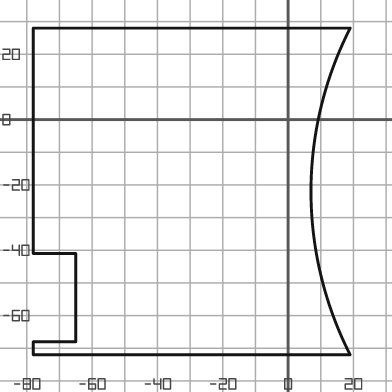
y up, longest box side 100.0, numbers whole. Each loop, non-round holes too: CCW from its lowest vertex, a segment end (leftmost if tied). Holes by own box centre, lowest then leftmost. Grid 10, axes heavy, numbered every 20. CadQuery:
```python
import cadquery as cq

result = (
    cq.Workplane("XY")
    .moveTo(-78.0, -72.0)
    .lineTo(19.0, -72.0)
    .threePointArc((7.0, -22.0), (19.0, 28.0))
    .lineTo(-78.0, 28.0)
    .lineTo(-78.0, -41.0)
    .lineTo(-65.0, -41.0)
    .lineTo(-65.0, -68.0)
    .lineTo(-78.0, -68.0)
    .close()
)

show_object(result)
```